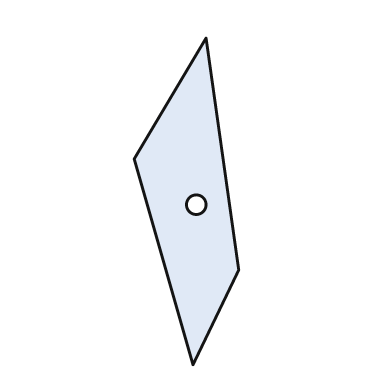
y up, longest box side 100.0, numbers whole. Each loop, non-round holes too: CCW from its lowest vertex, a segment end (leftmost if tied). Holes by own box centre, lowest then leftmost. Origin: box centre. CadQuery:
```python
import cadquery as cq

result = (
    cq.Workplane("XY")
    .moveTo(2.0, -50.0)
    .lineTo(16.0, -21.0)
    .lineTo(6.0, 50.0)
    .lineTo(-16.0, 13.0)
    .close()
    .moveTo(3.0, -1.0)
    .circle(3.0)
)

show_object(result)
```